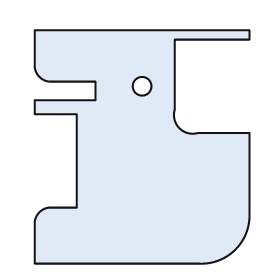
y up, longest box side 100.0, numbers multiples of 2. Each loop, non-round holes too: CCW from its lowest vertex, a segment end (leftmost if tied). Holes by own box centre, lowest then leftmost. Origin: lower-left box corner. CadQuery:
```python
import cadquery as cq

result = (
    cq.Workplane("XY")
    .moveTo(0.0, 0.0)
    .lineTo(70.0, 0.0)
    .threePointArc((86.0, 6.0), (92.0, 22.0))
    .lineTo(92.0, 56.0)
    .lineTo(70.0, 56.0)
    .threePointArc((62.0, 58.0), (60.0, 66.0))
    .lineTo(60.0, 96.0)
    .lineTo(92.0, 96.0)
    .lineTo(92.0, 100.0)
    .lineTo(0.0, 100.0)
    .lineTo(0.0, 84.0)
    .threePointArc((2.0, 80.0), (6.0, 78.0))
    .lineTo(26.0, 78.0)
    .lineTo(26.0, 70.0)
    .lineTo(0.0, 70.0)
    .lineTo(0.0, 64.0)
    .lineTo(18.0, 64.0)
    .lineTo(18.0, 24.0)
    .lineTo(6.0, 24.0)
    .threePointArc((2.0, 22.0), (0.0, 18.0))
    .close()
    .moveTo(46.0, 76.0)
    .circle(4.0)
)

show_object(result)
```